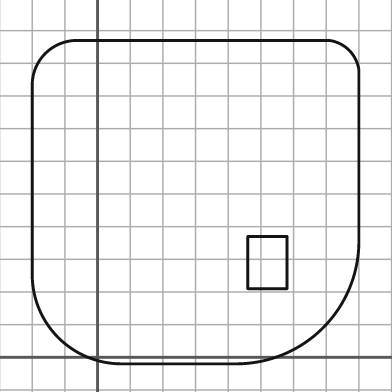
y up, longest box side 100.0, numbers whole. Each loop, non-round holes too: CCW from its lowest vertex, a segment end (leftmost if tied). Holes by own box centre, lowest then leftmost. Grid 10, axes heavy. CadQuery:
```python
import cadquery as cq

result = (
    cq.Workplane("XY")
    .moveTo(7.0, -2.0)
    .lineTo(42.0, -2.0)
    .threePointArc((69.0, 9.0), (80.0, 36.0))
    .lineTo(80.0, 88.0)
    .threePointArc((77.0, 94.0), (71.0, 97.0))
    .lineTo(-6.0, 97.0)
    .threePointArc((-16.0, 93.0), (-20.0, 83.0))
    .lineTo(-20.0, 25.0)
    .threePointArc((-12.0, 6.0), (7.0, -2.0))
    .close()
    .moveTo(46.0, 21.0)
    .lineTo(58.0, 21.0)
    .lineTo(58.0, 37.0)
    .lineTo(46.0, 37.0)
    .close()
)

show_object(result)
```